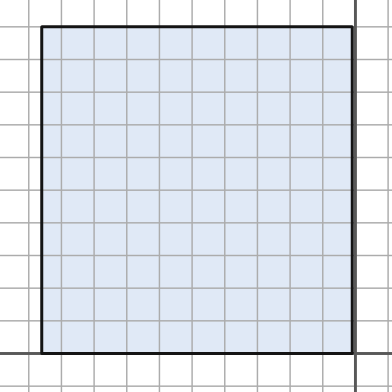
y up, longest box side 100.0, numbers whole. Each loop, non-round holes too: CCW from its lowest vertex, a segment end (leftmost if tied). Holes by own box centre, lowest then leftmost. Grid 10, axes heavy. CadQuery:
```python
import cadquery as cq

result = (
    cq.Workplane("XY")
    .moveTo(-96.0, 0.0)
    .lineTo(-1.0, 0.0)
    .lineTo(-1.0, 100.0)
    .lineTo(-96.0, 100.0)
    .close()
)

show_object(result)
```